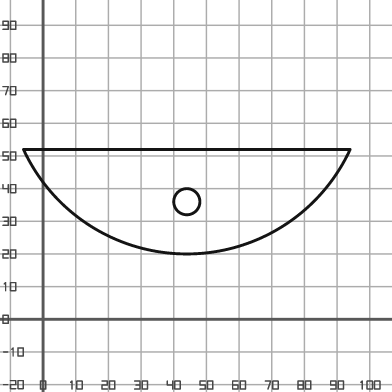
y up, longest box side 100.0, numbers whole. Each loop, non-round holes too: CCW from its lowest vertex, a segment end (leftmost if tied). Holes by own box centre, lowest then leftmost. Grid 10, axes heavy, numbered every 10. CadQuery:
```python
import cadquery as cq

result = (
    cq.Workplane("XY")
    .moveTo(-6.0, 52.0)
    .threePointArc((44.0, 20.0), (94.0, 52.0))
    .close()
    .moveTo(44.0, 36.0)
    .circle(4.0)
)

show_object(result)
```